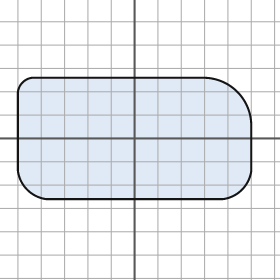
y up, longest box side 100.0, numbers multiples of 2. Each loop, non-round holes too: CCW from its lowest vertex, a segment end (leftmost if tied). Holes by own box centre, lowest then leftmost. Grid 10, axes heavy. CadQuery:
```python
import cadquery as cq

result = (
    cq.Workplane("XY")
    .moveTo(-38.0, -26.0)
    .lineTo(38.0, -26.0)
    .threePointArc((46.0, -22.0), (50.0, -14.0))
    .lineTo(50.0, 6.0)
    .threePointArc((44.0, 20.0), (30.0, 26.0))
    .lineTo(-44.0, 26.0)
    .threePointArc((-48.0, 24.0), (-50.0, 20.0))
    .lineTo(-50.0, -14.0)
    .threePointArc((-46.0, -22.0), (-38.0, -26.0))
    .close()
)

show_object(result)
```